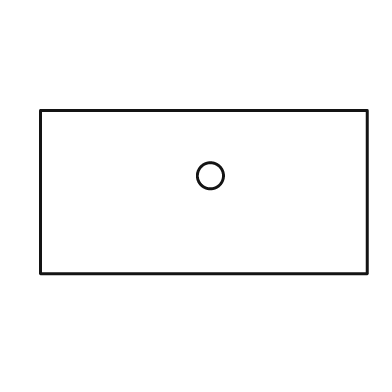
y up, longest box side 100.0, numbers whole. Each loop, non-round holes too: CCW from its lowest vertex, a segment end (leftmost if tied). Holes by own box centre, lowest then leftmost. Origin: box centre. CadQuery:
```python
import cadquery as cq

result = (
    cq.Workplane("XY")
    .moveTo(-50.0, -25.0)
    .lineTo(50.0, -25.0)
    .lineTo(50.0, 25.0)
    .lineTo(-50.0, 25.0)
    .close()
    .moveTo(2.0, 5.0)
    .circle(4.0)
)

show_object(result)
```